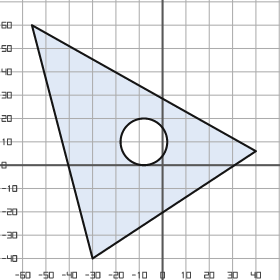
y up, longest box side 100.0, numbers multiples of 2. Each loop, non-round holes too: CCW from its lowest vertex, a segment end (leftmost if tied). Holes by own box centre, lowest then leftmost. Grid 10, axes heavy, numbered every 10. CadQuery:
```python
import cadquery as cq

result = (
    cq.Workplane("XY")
    .moveTo(-30.0, -40.0)
    .lineTo(40.0, 6.0)
    .lineTo(-56.0, 60.0)
    .close()
    .moveTo(-8.0, 10.0)
    .circle(10.0)
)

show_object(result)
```